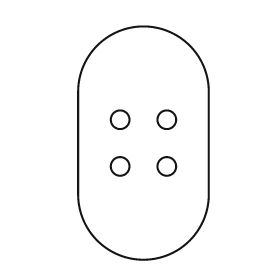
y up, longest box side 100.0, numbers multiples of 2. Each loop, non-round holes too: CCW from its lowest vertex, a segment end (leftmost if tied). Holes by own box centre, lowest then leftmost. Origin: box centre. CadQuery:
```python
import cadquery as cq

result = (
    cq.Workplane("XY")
    .moveTo(-28.0, -22.0)
    .threePointArc((0.0, -50.0), (28.0, -22.0))
    .lineTo(28.0, 22.0)
    .threePointArc((0.0, 50.0), (-28.0, 22.0))
    .close()
    .moveTo(-10.0, -10.0)
    .circle(4.0)
    .moveTo(10.0, -10.0)
    .circle(4.0)
    .moveTo(-10.0, 10.0)
    .circle(4.0)
    .moveTo(10.0, 10.0)
    .circle(4.0)
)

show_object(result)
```